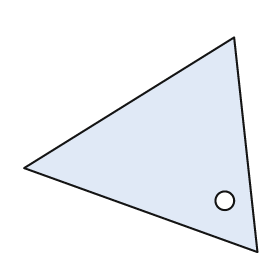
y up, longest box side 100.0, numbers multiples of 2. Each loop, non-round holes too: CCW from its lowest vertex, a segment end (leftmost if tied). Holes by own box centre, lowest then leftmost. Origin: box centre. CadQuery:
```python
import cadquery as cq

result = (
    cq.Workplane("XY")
    .moveTo(50.0, -46.0)
    .lineTo(40.0, 46.0)
    .lineTo(-50.0, -10.0)
    .close()
    .moveTo(36.0, -24.0)
    .circle(4.0)
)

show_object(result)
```